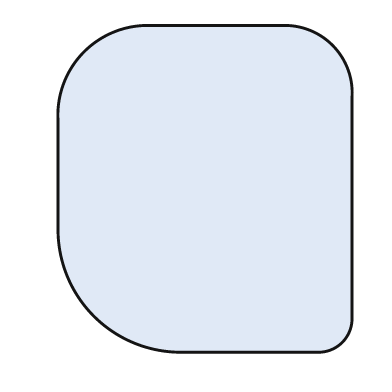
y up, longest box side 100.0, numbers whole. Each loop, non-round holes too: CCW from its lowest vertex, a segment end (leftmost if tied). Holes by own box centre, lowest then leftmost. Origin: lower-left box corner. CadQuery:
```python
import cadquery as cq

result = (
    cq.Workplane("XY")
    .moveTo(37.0, 0.0)
    .lineTo(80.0, 0.0)
    .threePointArc((87.0, 3.0), (90.0, 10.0))
    .lineTo(90.0, 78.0)
    .threePointArc((84.0, 94.0), (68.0, 100.0))
    .lineTo(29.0, 100.0)
    .threePointArc((8.0, 92.0), (0.0, 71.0))
    .lineTo(0.0, 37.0)
    .threePointArc((11.0, 11.0), (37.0, 0.0))
    .close()
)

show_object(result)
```